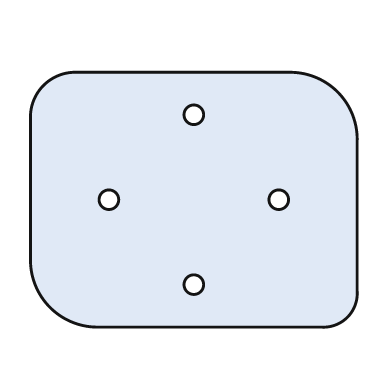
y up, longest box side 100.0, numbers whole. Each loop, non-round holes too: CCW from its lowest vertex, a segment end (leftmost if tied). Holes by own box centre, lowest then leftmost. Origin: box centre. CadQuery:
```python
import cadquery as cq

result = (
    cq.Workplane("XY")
    .moveTo(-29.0, -39.0)
    .lineTo(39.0, -39.0)
    .threePointArc((47.0, -36.0), (50.0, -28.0))
    .lineTo(50.0, 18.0)
    .threePointArc((44.0, 33.0), (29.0, 39.0))
    .lineTo(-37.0, 39.0)
    .threePointArc((-46.0, 35.0), (-50.0, 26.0))
    .lineTo(-50.0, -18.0)
    .threePointArc((-44.0, -33.0), (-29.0, -39.0))
    .close()
    .moveTo(0.0, -26.0)
    .circle(3.0)
    .moveTo(-26.0, 0.0)
    .circle(3.0)
    .moveTo(26.0, 0.0)
    .circle(3.0)
    .moveTo(0.0, 26.0)
    .circle(3.0)
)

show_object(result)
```